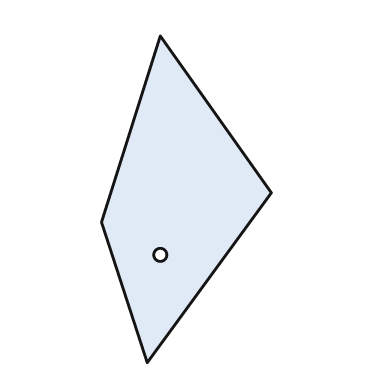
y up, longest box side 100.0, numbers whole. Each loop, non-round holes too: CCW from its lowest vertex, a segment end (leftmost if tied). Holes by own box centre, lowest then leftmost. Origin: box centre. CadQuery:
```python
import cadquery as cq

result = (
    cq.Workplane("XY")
    .moveTo(-12.0, -50.0)
    .lineTo(26.0, 2.0)
    .lineTo(-8.0, 50.0)
    .lineTo(-26.0, -7.0)
    .close()
    .moveTo(-8.0, -17.0)
    .circle(2.0)
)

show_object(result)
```